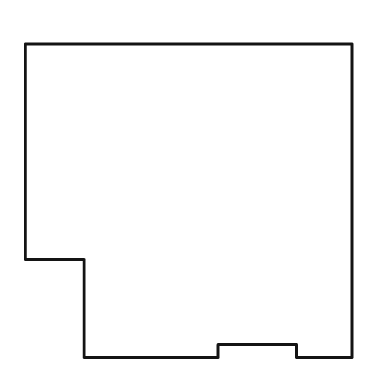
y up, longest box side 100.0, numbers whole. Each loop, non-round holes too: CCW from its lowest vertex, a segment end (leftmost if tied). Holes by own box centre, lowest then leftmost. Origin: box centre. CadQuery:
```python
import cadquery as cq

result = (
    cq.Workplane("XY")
    .moveTo(-32.0, -48.0)
    .lineTo(9.0, -48.0)
    .lineTo(9.0, -44.0)
    .lineTo(33.0, -44.0)
    .lineTo(33.0, -48.0)
    .lineTo(50.0, -48.0)
    .lineTo(50.0, 48.0)
    .lineTo(-50.0, 48.0)
    .lineTo(-50.0, -18.0)
    .lineTo(-32.0, -18.0)
    .close()
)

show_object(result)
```